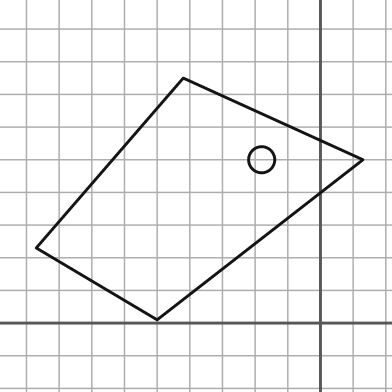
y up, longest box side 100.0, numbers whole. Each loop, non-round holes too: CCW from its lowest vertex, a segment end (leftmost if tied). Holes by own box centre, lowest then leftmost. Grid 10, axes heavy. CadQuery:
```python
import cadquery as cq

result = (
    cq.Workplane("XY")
    .moveTo(-50.0, 1.0)
    .lineTo(13.0, 50.0)
    .lineTo(-42.0, 75.0)
    .lineTo(-87.0, 23.0)
    .close()
    .moveTo(-18.0, 50.0)
    .circle(4.0)
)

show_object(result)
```